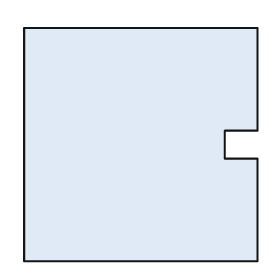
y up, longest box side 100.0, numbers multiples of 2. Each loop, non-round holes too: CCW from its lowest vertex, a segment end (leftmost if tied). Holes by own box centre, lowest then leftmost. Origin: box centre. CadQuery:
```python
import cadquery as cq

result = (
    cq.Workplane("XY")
    .moveTo(-50.0, -50.0)
    .lineTo(50.0, -50.0)
    .lineTo(50.0, -6.0)
    .lineTo(36.0, -6.0)
    .lineTo(36.0, 6.0)
    .lineTo(50.0, 6.0)
    .lineTo(50.0, 50.0)
    .lineTo(-50.0, 50.0)
    .close()
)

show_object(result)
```